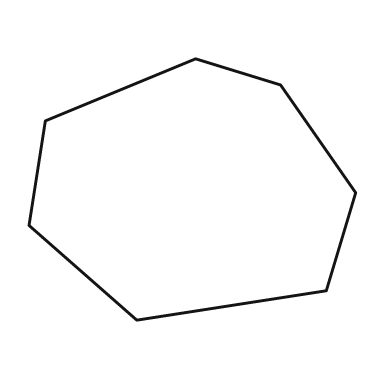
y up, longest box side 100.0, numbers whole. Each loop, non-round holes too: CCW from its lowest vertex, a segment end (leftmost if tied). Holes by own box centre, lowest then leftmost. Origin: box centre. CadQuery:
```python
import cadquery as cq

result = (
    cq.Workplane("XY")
    .moveTo(-17.0, -40.0)
    .lineTo(41.0, -31.0)
    .lineTo(50.0, -1.0)
    .lineTo(27.0, 32.0)
    .lineTo(1.0, 40.0)
    .lineTo(-45.0, 21.0)
    .lineTo(-50.0, -11.0)
    .close()
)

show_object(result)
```